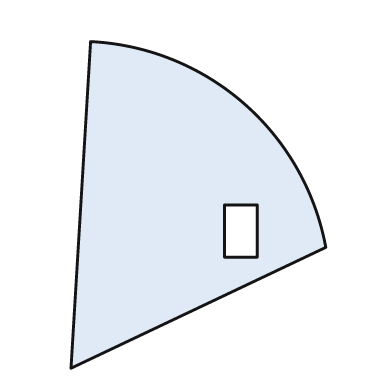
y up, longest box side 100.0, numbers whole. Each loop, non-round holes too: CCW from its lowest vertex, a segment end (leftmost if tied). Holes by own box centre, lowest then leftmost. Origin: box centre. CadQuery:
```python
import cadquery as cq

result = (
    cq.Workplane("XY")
    .moveTo(-39.0, -50.0)
    .lineTo(39.0, -13.0)
    .threePointArc((14.0, 31.0), (-33.0, 50.0))
    .close()
    .moveTo(8.0, -16.0)
    .lineTo(18.0, -16.0)
    .lineTo(18.0, 0.0)
    .lineTo(8.0, 0.0)
    .close()
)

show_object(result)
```